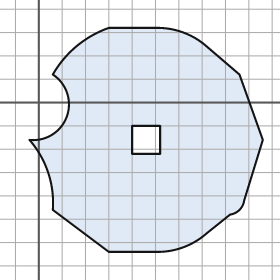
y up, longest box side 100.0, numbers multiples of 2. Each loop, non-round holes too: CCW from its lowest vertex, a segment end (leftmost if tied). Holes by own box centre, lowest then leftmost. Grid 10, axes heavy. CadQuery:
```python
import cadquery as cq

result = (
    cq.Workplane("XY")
    .moveTo(30.0, -64.0)
    .lineTo(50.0, -64.0)
    .threePointArc((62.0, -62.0), (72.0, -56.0))
    .lineTo(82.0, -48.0)
    .threePointArc((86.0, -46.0), (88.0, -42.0))
    .lineTo(96.0, -16.0)
    .lineTo(86.0, 12.0)
    .lineTo(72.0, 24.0)
    .threePointArc((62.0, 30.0), (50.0, 32.0))
    .lineTo(30.0, 32.0)
    .threePointArc((16.0, 24.0), (6.0, 12.0))
    .threePointArc((12.0, -6.0), (-4.0, -16.0))
    .threePointArc((4.0, -30.0), (6.0, -46.0))
    .close()
    .moveTo(40.0, -22.0)
    .lineTo(52.0, -22.0)
    .lineTo(52.0, -10.0)
    .lineTo(40.0, -10.0)
    .close()
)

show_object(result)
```